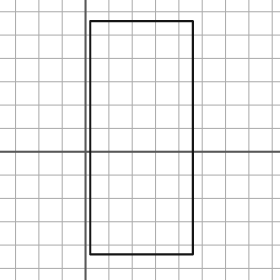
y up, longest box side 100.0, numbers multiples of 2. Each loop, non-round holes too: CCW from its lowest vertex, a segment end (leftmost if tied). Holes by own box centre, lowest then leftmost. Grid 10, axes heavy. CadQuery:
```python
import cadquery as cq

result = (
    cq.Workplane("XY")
    .moveTo(2.0, -44.0)
    .lineTo(46.0, -44.0)
    .lineTo(46.0, 56.0)
    .lineTo(2.0, 56.0)
    .close()
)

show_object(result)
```